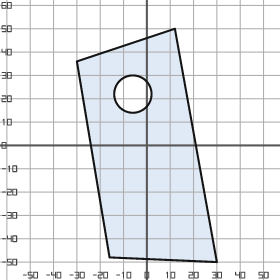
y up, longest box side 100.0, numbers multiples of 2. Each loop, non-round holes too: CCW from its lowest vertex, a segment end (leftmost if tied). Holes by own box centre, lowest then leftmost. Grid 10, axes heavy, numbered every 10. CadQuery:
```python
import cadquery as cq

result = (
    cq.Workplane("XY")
    .moveTo(30.0, -50.0)
    .lineTo(12.0, 50.0)
    .lineTo(-30.0, 36.0)
    .lineTo(-16.0, -48.0)
    .close()
    .moveTo(-6.0, 22.0)
    .circle(8.0)
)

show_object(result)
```